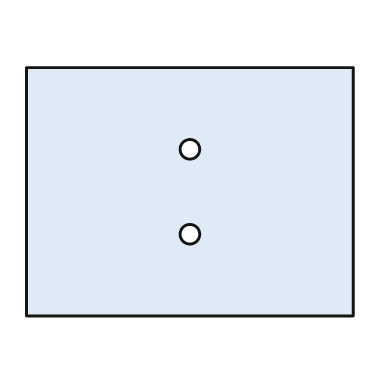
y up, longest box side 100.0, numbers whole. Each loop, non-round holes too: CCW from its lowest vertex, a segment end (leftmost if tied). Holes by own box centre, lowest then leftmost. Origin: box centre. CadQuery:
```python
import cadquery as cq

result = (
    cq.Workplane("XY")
    .moveTo(-50.0, -38.0)
    .lineTo(50.0, -38.0)
    .lineTo(50.0, 38.0)
    .lineTo(-50.0, 38.0)
    .close()
    .moveTo(0.0, -13.0)
    .circle(3.0)
    .moveTo(0.0, 13.0)
    .circle(3.0)
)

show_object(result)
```